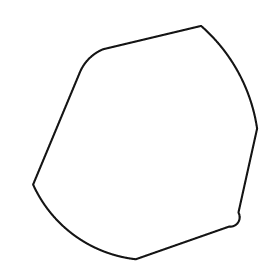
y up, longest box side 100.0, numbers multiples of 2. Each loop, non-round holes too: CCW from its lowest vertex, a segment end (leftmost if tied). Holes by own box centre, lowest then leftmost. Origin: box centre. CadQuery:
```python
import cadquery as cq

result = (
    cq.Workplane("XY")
    .moveTo(-4.0, -50.0)
    .lineTo(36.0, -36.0)
    .threePointArc((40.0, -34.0), (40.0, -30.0))
    .lineTo(48.0, 6.0)
    .threePointArc((40.0, 30.0), (24.0, 50.0))
    .lineTo(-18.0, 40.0)
    .threePointArc((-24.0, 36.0), (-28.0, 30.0))
    .lineTo(-48.0, -18.0)
    .threePointArc((-30.0, -40.0), (-4.0, -50.0))
    .close()
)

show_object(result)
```